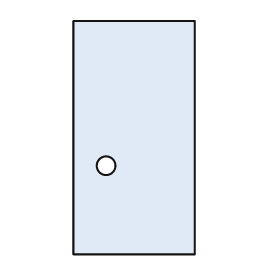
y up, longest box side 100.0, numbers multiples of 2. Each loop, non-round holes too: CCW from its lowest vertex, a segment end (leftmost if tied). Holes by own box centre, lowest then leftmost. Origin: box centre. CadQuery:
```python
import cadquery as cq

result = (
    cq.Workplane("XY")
    .moveTo(-26.0, -50.0)
    .lineTo(26.0, -50.0)
    .lineTo(26.0, 50.0)
    .lineTo(-26.0, 50.0)
    .close()
    .moveTo(-12.0, -12.0)
    .circle(4.0)
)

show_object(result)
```